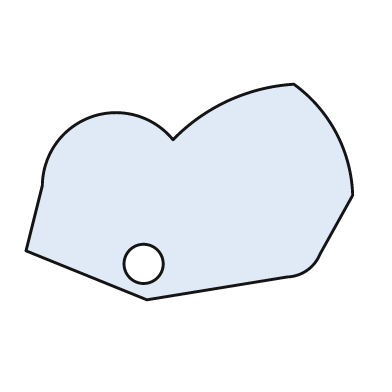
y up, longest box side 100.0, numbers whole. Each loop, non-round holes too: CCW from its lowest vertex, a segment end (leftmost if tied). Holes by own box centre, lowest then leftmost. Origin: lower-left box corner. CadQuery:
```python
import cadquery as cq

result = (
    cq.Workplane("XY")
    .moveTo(37.0, 0.0)
    .lineTo(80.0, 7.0)
    .threePointArc((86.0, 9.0), (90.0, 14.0))
    .lineTo(100.0, 32.0)
    .threePointArc((95.0, 51.0), (82.0, 66.0))
    .threePointArc((62.0, 61.0), (45.0, 49.0))
    .threePointArc((20.0, 56.0), (5.0, 35.0))
    .lineTo(0.0, 15.0)
    .close()
    .moveTo(36.0, 11.0)
    .circle(6.0)
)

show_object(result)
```